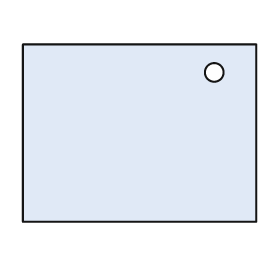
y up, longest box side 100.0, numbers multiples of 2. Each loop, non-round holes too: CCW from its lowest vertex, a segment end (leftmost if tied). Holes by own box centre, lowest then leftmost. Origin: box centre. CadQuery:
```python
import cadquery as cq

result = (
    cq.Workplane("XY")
    .moveTo(-50.0, -38.0)
    .lineTo(50.0, -38.0)
    .lineTo(50.0, 38.0)
    .lineTo(-50.0, 38.0)
    .close()
    .moveTo(32.0, 26.0)
    .circle(4.0)
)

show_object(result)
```